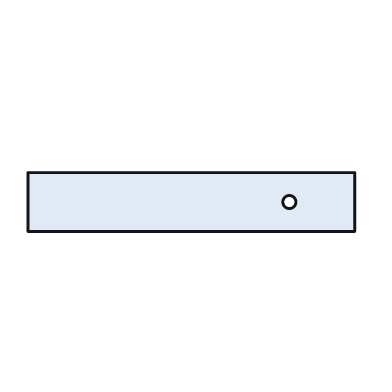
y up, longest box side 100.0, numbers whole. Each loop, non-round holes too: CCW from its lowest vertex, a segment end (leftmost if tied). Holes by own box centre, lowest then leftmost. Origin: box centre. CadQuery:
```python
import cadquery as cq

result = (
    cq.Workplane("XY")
    .moveTo(-50.0, -9.0)
    .lineTo(50.0, -9.0)
    .lineTo(50.0, 9.0)
    .lineTo(-50.0, 9.0)
    .close()
    .moveTo(30.0, 0.0)
    .circle(2.0)
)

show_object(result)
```